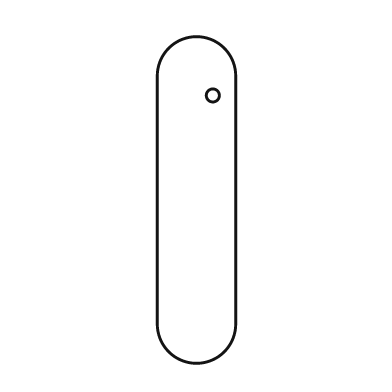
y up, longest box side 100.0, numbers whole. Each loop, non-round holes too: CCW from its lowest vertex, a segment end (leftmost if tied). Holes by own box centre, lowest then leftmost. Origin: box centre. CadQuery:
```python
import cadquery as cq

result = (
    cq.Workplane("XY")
    .moveTo(-12.0, -38.0)
    .threePointArc((0.0, -50.0), (12.0, -38.0))
    .lineTo(12.0, 38.0)
    .threePointArc((0.0, 50.0), (-12.0, 38.0))
    .close()
    .moveTo(5.0, 32.0)
    .circle(2.0)
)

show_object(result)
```